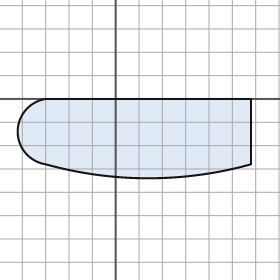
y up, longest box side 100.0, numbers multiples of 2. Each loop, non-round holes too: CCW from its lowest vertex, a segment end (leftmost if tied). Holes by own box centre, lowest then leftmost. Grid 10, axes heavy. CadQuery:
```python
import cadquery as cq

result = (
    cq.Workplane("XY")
    .moveTo(-30.0, -28.0)
    .threePointArc((14.0, -34.0), (58.0, -28.0))
    .lineTo(58.0, 0.0)
    .lineTo(-30.0, 0.0)
    .threePointArc((-42.0, -14.0), (-30.0, -28.0))
    .close()
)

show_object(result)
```